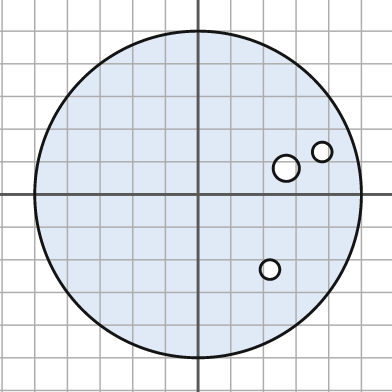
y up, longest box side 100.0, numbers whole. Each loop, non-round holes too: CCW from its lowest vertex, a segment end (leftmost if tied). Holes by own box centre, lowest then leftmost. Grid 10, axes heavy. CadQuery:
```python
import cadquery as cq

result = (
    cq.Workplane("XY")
    .moveTo(0.0, 0.0)
    .circle(50.0)
    .moveTo(22.0, -23.0)
    .circle(3.0)
    .moveTo(27.0, 8.0)
    .circle(4.0)
    .moveTo(38.0, 13.0)
    .circle(3.0)
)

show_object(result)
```